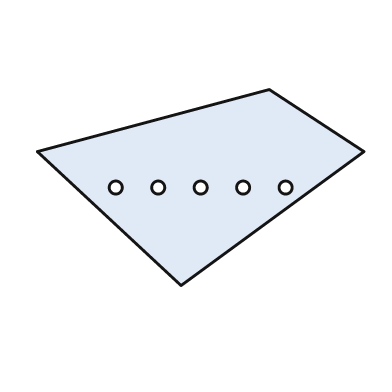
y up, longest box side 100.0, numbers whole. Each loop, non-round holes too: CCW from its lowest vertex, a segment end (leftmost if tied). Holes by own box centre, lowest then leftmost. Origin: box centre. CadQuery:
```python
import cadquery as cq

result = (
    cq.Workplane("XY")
    .moveTo(-6.0, -30.0)
    .lineTo(50.0, 11.0)
    .lineTo(21.0, 30.0)
    .lineTo(-50.0, 11.0)
    .close()
    .moveTo(-26.0, 0.0)
    .circle(2.0)
    .moveTo(-13.0, 0.0)
    .circle(2.0)
    .moveTo(0.0, 0.0)
    .circle(2.0)
    .moveTo(13.0, 0.0)
    .circle(2.0)
    .moveTo(26.0, 0.0)
    .circle(2.0)
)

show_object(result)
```